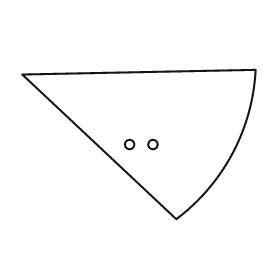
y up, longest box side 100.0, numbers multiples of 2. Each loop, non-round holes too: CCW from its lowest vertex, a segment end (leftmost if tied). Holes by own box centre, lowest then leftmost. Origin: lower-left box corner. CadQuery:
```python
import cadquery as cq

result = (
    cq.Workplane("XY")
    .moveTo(66.0, 0.0)
    .threePointArc((90.0, 28.0), (100.0, 64.0))
    .lineTo(0.0, 62.0)
    .close()
    .moveTo(46.0, 32.0)
    .circle(2.0)
    .moveTo(56.0, 32.0)
    .circle(2.0)
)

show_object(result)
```